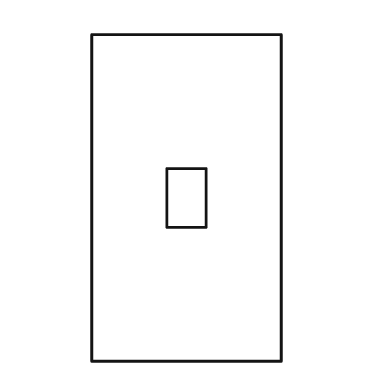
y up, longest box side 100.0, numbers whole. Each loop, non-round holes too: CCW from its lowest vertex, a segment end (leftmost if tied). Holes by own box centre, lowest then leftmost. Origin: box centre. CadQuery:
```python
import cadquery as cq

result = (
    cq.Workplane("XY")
    .moveTo(-29.0, -50.0)
    .lineTo(29.0, -50.0)
    .lineTo(29.0, 50.0)
    .lineTo(-29.0, 50.0)
    .close()
    .moveTo(-6.0, -9.0)
    .lineTo(6.0, -9.0)
    .lineTo(6.0, 9.0)
    .lineTo(-6.0, 9.0)
    .close()
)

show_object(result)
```